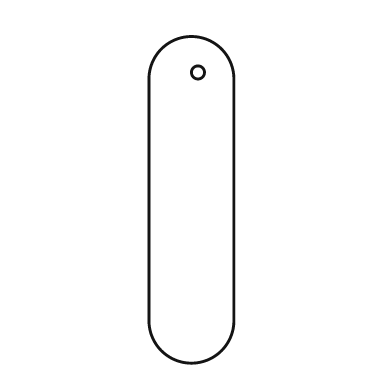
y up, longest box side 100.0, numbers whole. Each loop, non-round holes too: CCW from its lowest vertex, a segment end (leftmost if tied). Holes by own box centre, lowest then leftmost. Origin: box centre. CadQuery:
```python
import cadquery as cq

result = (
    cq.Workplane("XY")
    .moveTo(-13.0, -37.0)
    .threePointArc((0.0, -50.0), (13.0, -37.0))
    .lineTo(13.0, 37.0)
    .threePointArc((0.0, 50.0), (-13.0, 37.0))
    .close()
    .moveTo(2.0, 39.0)
    .circle(2.0)
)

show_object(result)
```